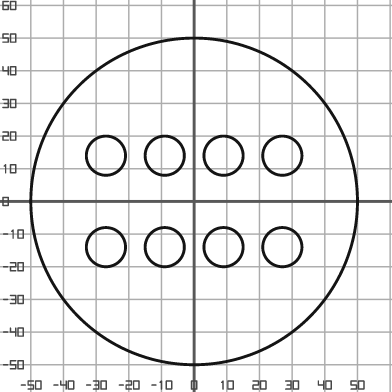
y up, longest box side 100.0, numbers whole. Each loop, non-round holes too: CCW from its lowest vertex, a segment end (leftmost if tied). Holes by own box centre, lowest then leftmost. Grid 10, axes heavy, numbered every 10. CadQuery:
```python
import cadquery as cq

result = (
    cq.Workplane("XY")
    .moveTo(0.0, 0.0)
    .circle(50.0)
    .moveTo(-27.0, -14.0)
    .circle(6.0)
    .moveTo(-9.0, -14.0)
    .circle(6.0)
    .moveTo(9.0, -14.0)
    .circle(6.0)
    .moveTo(27.0, -14.0)
    .circle(6.0)
    .moveTo(-27.0, 14.0)
    .circle(6.0)
    .moveTo(-9.0, 14.0)
    .circle(6.0)
    .moveTo(9.0, 14.0)
    .circle(6.0)
    .moveTo(27.0, 14.0)
    .circle(6.0)
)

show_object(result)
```